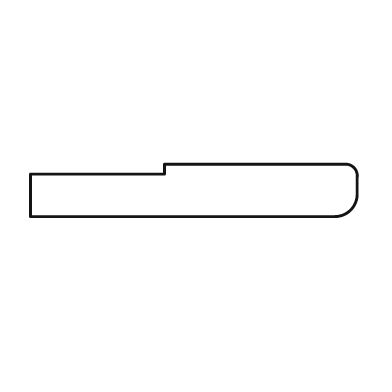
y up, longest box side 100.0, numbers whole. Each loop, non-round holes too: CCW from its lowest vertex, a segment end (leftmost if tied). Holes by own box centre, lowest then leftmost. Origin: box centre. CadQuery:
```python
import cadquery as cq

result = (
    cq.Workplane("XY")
    .moveTo(-50.0, -8.0)
    .lineTo(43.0, -8.0)
    .threePointArc((48.0, -6.0), (50.0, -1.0))
    .lineTo(50.0, 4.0)
    .threePointArc((49.0, 7.0), (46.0, 8.0))
    .lineTo(-9.0, 8.0)
    .lineTo(-9.0, 5.0)
    .lineTo(-50.0, 5.0)
    .close()
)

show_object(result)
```